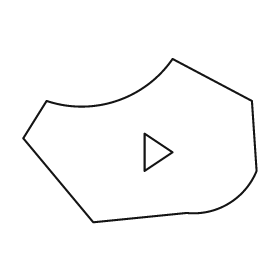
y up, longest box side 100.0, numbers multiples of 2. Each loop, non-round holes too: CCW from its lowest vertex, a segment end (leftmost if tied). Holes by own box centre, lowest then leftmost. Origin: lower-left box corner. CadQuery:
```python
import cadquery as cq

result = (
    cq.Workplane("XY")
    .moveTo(30.0, 0.0)
    .lineTo(70.0, 4.0)
    .threePointArc((88.0, 8.0), (100.0, 22.0))
    .lineTo(98.0, 52.0)
    .lineTo(64.0, 70.0)
    .threePointArc((40.0, 52.0), (10.0, 52.0))
    .lineTo(0.0, 36.0)
    .close()
    .moveTo(52.0, 22.0)
    .lineTo(64.0, 30.0)
    .lineTo(52.0, 38.0)
    .close()
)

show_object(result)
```